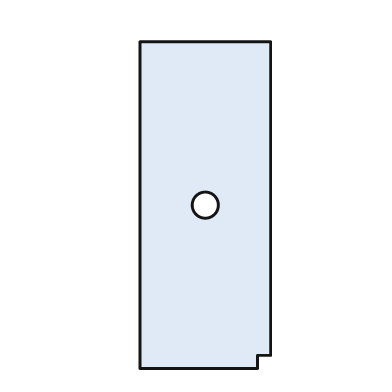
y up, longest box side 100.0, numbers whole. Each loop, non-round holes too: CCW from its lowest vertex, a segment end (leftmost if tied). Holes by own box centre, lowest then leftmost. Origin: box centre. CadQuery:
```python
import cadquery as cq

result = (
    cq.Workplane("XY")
    .moveTo(-20.0, -50.0)
    .lineTo(16.0, -50.0)
    .lineTo(16.0, -46.0)
    .lineTo(20.0, -46.0)
    .lineTo(20.0, 50.0)
    .lineTo(-20.0, 50.0)
    .close()
    .moveTo(0.0, 0.0)
    .circle(4.0)
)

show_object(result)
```